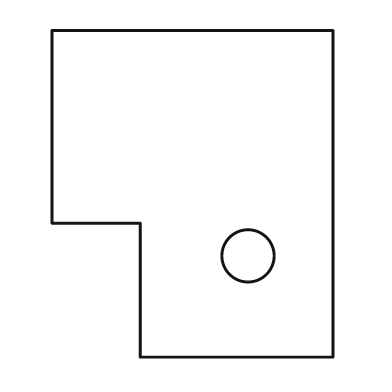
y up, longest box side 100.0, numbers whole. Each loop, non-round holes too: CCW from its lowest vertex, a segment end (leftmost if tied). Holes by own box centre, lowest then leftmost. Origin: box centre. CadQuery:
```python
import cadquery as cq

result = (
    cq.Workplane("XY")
    .moveTo(-16.0, -50.0)
    .lineTo(43.0, -50.0)
    .lineTo(43.0, 50.0)
    .lineTo(-43.0, 50.0)
    .lineTo(-43.0, -9.0)
    .lineTo(-16.0, -9.0)
    .close()
    .moveTo(17.0, -19.0)
    .circle(8.0)
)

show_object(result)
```